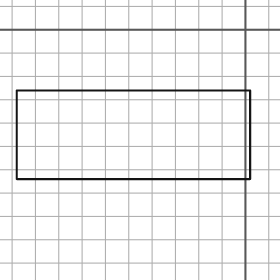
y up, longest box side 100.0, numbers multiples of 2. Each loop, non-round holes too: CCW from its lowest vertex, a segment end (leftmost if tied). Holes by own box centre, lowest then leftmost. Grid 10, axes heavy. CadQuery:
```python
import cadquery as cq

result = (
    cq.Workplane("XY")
    .moveTo(-98.0, -64.0)
    .lineTo(2.0, -64.0)
    .lineTo(2.0, -26.0)
    .lineTo(-98.0, -26.0)
    .close()
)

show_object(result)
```